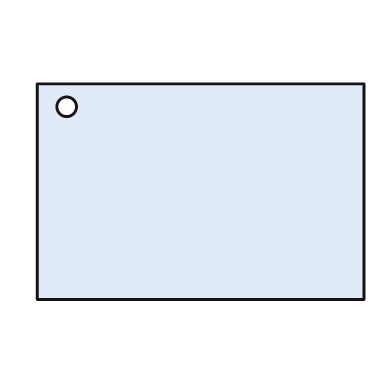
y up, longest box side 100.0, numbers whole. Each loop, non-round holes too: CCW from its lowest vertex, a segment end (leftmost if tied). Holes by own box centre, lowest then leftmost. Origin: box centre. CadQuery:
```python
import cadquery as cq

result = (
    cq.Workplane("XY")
    .moveTo(-50.0, -33.0)
    .lineTo(50.0, -33.0)
    .lineTo(50.0, 33.0)
    .lineTo(-50.0, 33.0)
    .close()
    .moveTo(-41.0, 26.0)
    .circle(3.0)
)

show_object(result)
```